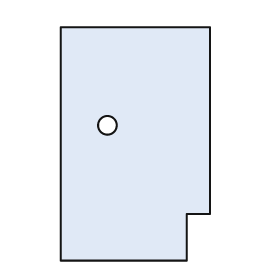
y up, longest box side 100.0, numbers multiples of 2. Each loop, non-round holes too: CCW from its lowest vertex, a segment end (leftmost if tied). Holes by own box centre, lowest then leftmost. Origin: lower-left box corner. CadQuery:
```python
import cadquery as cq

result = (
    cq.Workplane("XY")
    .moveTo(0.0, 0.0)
    .lineTo(54.0, 0.0)
    .lineTo(54.0, 20.0)
    .lineTo(64.0, 20.0)
    .lineTo(64.0, 100.0)
    .lineTo(0.0, 100.0)
    .close()
    .moveTo(20.0, 58.0)
    .circle(4.0)
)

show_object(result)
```